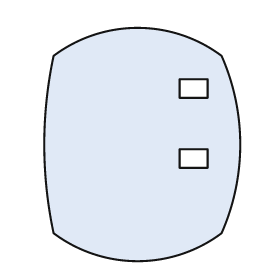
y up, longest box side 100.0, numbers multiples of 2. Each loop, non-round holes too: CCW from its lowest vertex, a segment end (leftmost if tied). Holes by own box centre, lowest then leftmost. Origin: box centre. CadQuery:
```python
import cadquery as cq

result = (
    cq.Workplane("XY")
    .moveTo(-38.0, -38.0)
    .threePointArc((-2.0, -50.0), (34.0, -38.0))
    .threePointArc((42.0, 0.0), (34.0, 38.0))
    .threePointArc((-2.0, 50.0), (-38.0, 38.0))
    .threePointArc((-42.0, 0.0), (-38.0, -38.0))
    .close()
    .moveTo(16.0, -10.0)
    .lineTo(28.0, -10.0)
    .lineTo(28.0, -2.0)
    .lineTo(16.0, -2.0)
    .close()
    .moveTo(16.0, 20.0)
    .lineTo(28.0, 20.0)
    .lineTo(28.0, 28.0)
    .lineTo(16.0, 28.0)
    .close()
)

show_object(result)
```